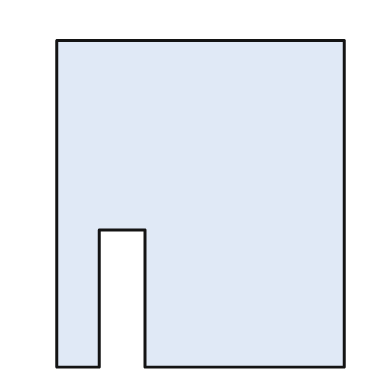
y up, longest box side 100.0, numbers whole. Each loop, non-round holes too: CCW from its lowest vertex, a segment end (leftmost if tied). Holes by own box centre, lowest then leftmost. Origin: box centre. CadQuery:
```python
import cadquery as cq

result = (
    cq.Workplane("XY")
    .moveTo(-44.0, -50.0)
    .lineTo(-31.0, -50.0)
    .lineTo(-31.0, -8.0)
    .lineTo(-17.0, -8.0)
    .lineTo(-17.0, -50.0)
    .lineTo(44.0, -50.0)
    .lineTo(44.0, 50.0)
    .lineTo(-44.0, 50.0)
    .close()
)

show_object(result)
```